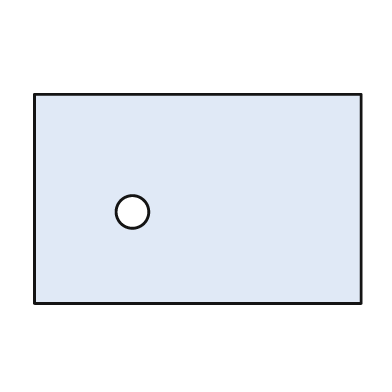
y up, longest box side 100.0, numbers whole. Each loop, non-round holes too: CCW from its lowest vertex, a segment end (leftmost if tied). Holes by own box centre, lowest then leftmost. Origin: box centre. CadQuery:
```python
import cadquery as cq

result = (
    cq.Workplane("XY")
    .moveTo(-50.0, -32.0)
    .lineTo(50.0, -32.0)
    .lineTo(50.0, 32.0)
    .lineTo(-50.0, 32.0)
    .close()
    .moveTo(-20.0, -4.0)
    .circle(5.0)
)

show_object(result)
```